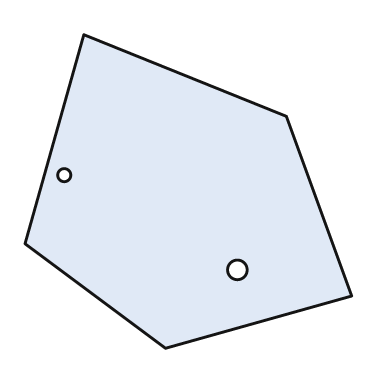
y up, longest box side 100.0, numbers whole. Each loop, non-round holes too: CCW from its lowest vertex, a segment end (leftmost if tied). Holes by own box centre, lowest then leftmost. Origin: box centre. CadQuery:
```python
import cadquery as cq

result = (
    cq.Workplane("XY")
    .moveTo(-7.0, -48.0)
    .lineTo(50.0, -32.0)
    .lineTo(30.0, 23.0)
    .lineTo(-32.0, 48.0)
    .lineTo(-50.0, -16.0)
    .close()
    .moveTo(15.0, -24.0)
    .circle(3.0)
    .moveTo(-38.0, 5.0)
    .circle(2.0)
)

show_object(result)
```